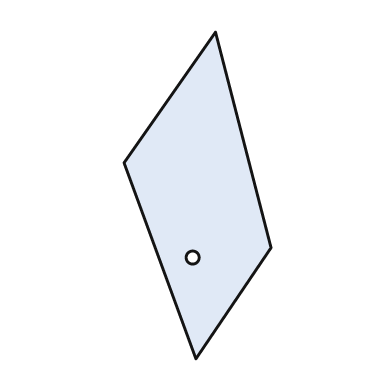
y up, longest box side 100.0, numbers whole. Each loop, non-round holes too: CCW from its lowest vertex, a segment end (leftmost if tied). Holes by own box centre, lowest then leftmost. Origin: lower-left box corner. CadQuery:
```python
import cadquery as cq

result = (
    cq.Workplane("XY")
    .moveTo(22.0, 0.0)
    .lineTo(45.0, 34.0)
    .lineTo(28.0, 100.0)
    .lineTo(0.0, 60.0)
    .close()
    .moveTo(21.0, 31.0)
    .circle(2.0)
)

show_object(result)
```